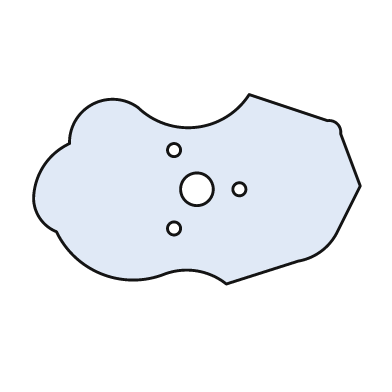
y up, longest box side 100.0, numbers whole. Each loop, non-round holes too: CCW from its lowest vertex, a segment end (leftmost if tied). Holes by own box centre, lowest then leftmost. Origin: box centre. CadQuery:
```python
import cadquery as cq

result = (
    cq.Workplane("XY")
    .moveTo(9.0, -29.0)
    .lineTo(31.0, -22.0)
    .threePointArc((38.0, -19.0), (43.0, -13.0))
    .lineTo(50.0, 1.0)
    .lineTo(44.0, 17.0)
    .threePointArc((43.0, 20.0), (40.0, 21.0))
    .lineTo(16.0, 29.0)
    .threePointArc((0.0, 19.0), (-18.0, 25.0))
    .threePointArc((-32.0, 26.0), (-39.0, 14.0))
    .threePointArc((-47.0, 7.0), (-50.0, -3.0))
    .threePointArc((-48.0, -9.0), (-43.0, -13.0))
    .threePointArc((-29.0, -26.0), (-10.0, -26.0))
    .threePointArc((0.0, -25.0), (9.0, -29.0))
    .close()
    .moveTo(-7.0, -12.0)
    .circle(2.0)
    .moveTo(0.0, 0.0)
    .circle(5.0)
    .moveTo(13.0, 0.0)
    .circle(2.0)
    .moveTo(-7.0, 12.0)
    .circle(2.0)
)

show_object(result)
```